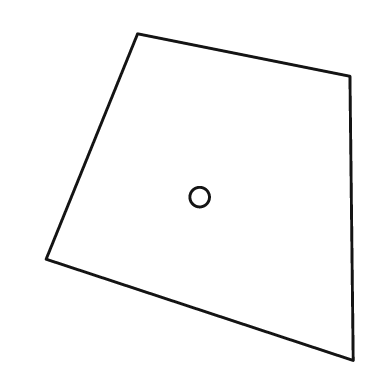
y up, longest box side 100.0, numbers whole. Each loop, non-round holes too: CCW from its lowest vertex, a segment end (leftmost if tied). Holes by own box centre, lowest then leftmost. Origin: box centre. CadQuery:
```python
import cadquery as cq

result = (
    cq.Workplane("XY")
    .moveTo(47.0, -50.0)
    .lineTo(46.0, 37.0)
    .lineTo(-19.0, 50.0)
    .lineTo(-47.0, -19.0)
    .close()
    .moveTo(0.0, 0.0)
    .circle(3.0)
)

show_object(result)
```